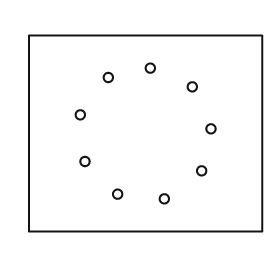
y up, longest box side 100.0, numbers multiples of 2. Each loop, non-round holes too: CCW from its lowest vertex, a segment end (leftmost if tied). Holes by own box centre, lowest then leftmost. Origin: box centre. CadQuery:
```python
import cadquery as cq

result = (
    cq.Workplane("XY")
    .moveTo(-50.0, -42.0)
    .lineTo(50.0, -42.0)
    .lineTo(50.0, 42.0)
    .lineTo(-50.0, 42.0)
    .close()
    .moveTo(8.0, -28.0)
    .circle(2.0)
    .moveTo(-12.0, -26.0)
    .circle(2.0)
    .moveTo(24.0, -16.0)
    .circle(2.0)
    .moveTo(-26.0, -12.0)
    .circle(2.0)
    .moveTo(28.0, 2.0)
    .circle(2.0)
    .moveTo(-28.0, 8.0)
    .circle(2.0)
    .moveTo(20.0, 20.0)
    .circle(2.0)
    .moveTo(-16.0, 24.0)
    .circle(2.0)
    .moveTo(2.0, 28.0)
    .circle(2.0)
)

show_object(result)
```